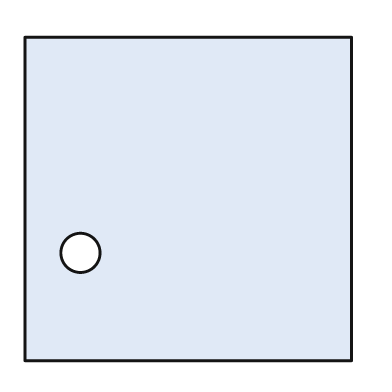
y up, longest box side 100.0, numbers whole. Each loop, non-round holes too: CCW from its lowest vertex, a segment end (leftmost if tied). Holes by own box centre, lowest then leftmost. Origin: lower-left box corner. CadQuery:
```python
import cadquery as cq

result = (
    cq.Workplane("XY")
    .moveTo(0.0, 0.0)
    .lineTo(100.0, 0.0)
    .lineTo(100.0, 99.0)
    .lineTo(0.0, 99.0)
    .close()
    .moveTo(17.0, 33.0)
    .circle(6.0)
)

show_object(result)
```